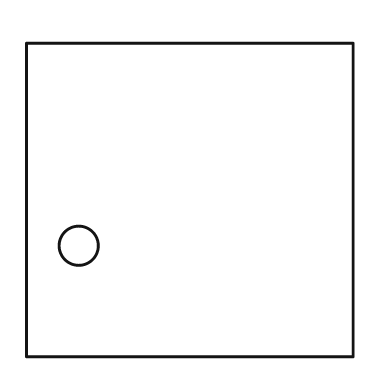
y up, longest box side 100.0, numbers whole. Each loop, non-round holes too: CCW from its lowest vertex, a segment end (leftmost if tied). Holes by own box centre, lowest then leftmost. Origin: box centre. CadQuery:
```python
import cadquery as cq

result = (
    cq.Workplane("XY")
    .moveTo(-50.0, -48.0)
    .lineTo(50.0, -48.0)
    .lineTo(50.0, 48.0)
    .lineTo(-50.0, 48.0)
    .close()
    .moveTo(-34.0, -14.0)
    .circle(6.0)
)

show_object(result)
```